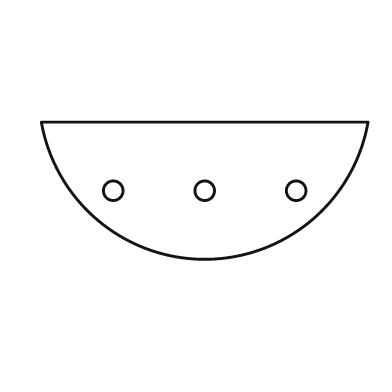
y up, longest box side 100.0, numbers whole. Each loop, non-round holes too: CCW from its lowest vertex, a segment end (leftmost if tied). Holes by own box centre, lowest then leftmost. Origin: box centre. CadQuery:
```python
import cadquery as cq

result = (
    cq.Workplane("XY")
    .moveTo(-50.0, 21.0)
    .threePointArc((0.0, -21.0), (50.0, 21.0))
    .close()
    .moveTo(-28.0, 0.0)
    .circle(3.0)
    .moveTo(0.0, 0.0)
    .circle(3.0)
    .moveTo(28.0, 0.0)
    .circle(3.0)
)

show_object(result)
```